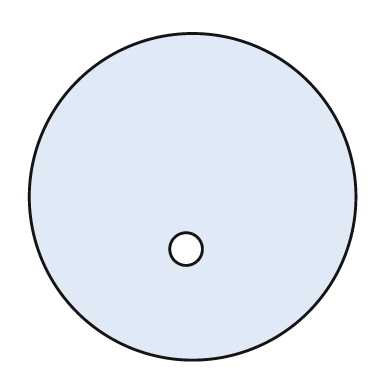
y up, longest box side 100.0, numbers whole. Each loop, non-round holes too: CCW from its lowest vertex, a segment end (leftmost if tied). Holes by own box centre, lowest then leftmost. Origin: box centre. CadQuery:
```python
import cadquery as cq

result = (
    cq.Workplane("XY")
    .moveTo(0.0, 0.0)
    .circle(50.0)
    .moveTo(-2.0, -16.0)
    .circle(5.0)
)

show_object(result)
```